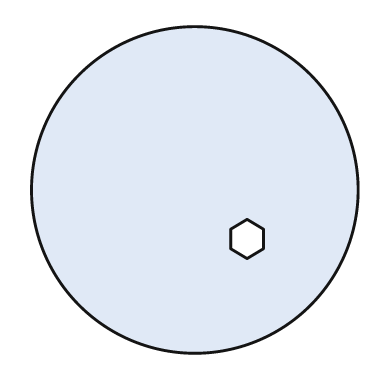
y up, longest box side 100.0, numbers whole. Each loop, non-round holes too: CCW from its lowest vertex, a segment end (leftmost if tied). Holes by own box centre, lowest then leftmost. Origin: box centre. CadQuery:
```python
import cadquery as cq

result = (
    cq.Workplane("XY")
    .moveTo(0.0, 0.0)
    .circle(50.0)
    .moveTo(16.0, -21.0)
    .lineTo(21.0, -18.0)
    .lineTo(21.0, -12.0)
    .lineTo(16.0, -9.0)
    .lineTo(11.0, -12.0)
    .lineTo(11.0, -18.0)
    .close()
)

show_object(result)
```